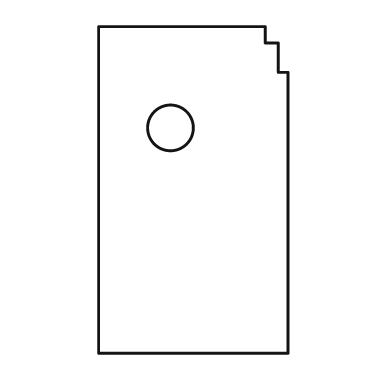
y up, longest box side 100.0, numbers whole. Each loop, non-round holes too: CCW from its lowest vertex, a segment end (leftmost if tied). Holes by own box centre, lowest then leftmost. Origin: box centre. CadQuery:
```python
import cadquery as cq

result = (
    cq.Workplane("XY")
    .moveTo(-29.0, -50.0)
    .lineTo(29.0, -50.0)
    .lineTo(29.0, 36.0)
    .lineTo(26.0, 36.0)
    .lineTo(26.0, 45.0)
    .lineTo(22.0, 45.0)
    .lineTo(22.0, 50.0)
    .lineTo(-29.0, 50.0)
    .close()
    .moveTo(-7.0, 19.0)
    .circle(7.0)
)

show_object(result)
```